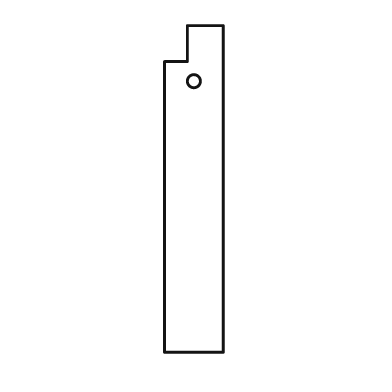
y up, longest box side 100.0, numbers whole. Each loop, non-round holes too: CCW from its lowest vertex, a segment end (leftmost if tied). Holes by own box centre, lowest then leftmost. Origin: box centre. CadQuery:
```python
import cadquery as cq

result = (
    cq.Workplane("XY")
    .moveTo(-9.0, -50.0)
    .lineTo(9.0, -50.0)
    .lineTo(9.0, 50.0)
    .lineTo(-2.0, 50.0)
    .lineTo(-2.0, 39.0)
    .lineTo(-9.0, 39.0)
    .close()
    .moveTo(0.0, 33.0)
    .circle(2.0)
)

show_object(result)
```